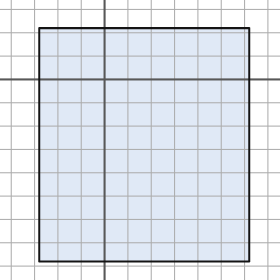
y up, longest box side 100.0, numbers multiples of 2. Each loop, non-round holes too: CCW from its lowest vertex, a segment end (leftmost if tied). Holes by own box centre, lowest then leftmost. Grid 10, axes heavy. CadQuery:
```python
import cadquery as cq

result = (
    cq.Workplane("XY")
    .moveTo(-28.0, -78.0)
    .lineTo(62.0, -78.0)
    .lineTo(62.0, 22.0)
    .lineTo(-28.0, 22.0)
    .close()
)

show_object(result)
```